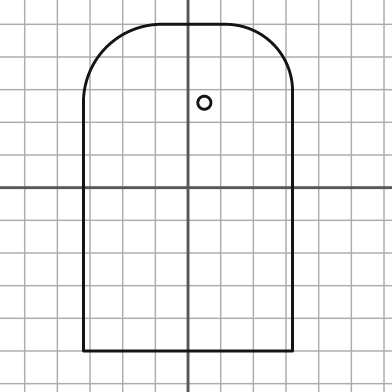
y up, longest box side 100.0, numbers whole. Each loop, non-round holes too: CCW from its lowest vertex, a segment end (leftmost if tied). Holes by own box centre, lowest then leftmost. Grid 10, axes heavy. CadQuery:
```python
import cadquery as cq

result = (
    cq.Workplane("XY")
    .moveTo(-32.0, -50.0)
    .lineTo(32.0, -50.0)
    .lineTo(32.0, 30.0)
    .threePointArc((26.0, 44.0), (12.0, 50.0))
    .lineTo(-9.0, 50.0)
    .threePointArc((-25.0, 43.0), (-32.0, 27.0))
    .close()
    .moveTo(5.0, 26.0)
    .circle(2.0)
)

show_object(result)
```